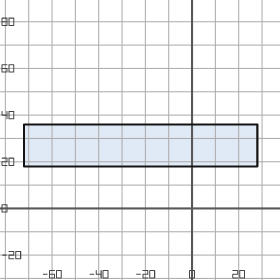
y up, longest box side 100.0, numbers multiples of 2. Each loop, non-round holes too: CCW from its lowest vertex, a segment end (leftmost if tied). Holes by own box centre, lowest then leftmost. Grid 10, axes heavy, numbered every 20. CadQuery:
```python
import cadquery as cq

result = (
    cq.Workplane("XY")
    .moveTo(-72.0, 18.0)
    .lineTo(28.0, 18.0)
    .lineTo(28.0, 36.0)
    .lineTo(-72.0, 36.0)
    .close()
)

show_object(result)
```